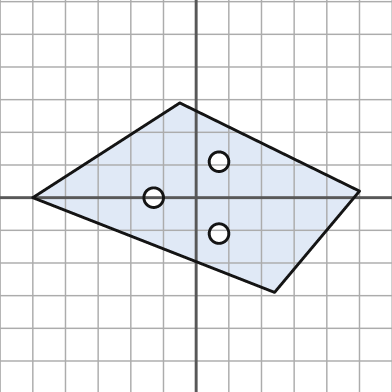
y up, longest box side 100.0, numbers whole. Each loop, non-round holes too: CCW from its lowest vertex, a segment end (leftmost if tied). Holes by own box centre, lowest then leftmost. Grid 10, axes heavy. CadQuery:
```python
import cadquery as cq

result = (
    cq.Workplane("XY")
    .moveTo(24.0, -29.0)
    .lineTo(50.0, 2.0)
    .lineTo(-5.0, 29.0)
    .lineTo(-50.0, 0.0)
    .close()
    .moveTo(7.0, -11.0)
    .circle(3.0)
    .moveTo(-13.0, 0.0)
    .circle(3.0)
    .moveTo(7.0, 11.0)
    .circle(3.0)
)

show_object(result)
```